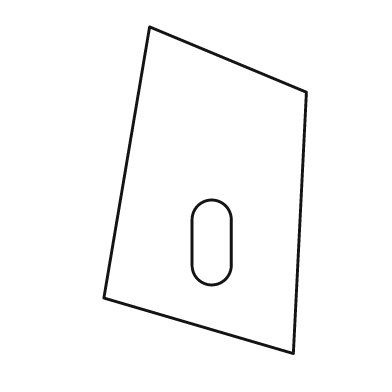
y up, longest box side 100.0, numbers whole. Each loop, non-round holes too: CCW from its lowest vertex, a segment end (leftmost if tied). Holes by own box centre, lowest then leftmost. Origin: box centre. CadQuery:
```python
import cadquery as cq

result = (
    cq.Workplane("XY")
    .moveTo(27.0, -50.0)
    .lineTo(31.0, 30.0)
    .lineTo(-17.0, 50.0)
    .lineTo(-31.0, -33.0)
    .close()
    .moveTo(-4.0, -23.0)
    .threePointArc((2.0, -29.0), (8.0, -23.0))
    .lineTo(8.0, -9.0)
    .threePointArc((2.0, -3.0), (-4.0, -9.0))
    .close()
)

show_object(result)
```